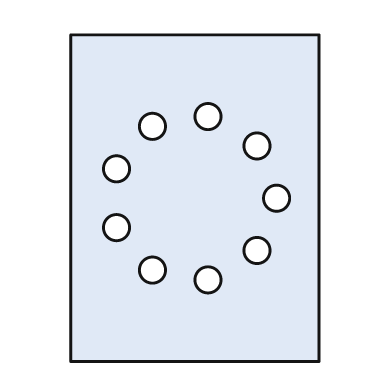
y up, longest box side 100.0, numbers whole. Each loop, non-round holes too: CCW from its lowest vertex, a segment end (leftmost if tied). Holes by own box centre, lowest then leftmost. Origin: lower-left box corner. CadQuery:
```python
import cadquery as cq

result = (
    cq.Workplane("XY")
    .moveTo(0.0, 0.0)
    .lineTo(76.0, 0.0)
    .lineTo(76.0, 100.0)
    .lineTo(0.0, 100.0)
    .close()
    .moveTo(42.0, 25.0)
    .circle(4.0)
    .moveTo(25.0, 28.0)
    .circle(4.0)
    .moveTo(57.0, 34.0)
    .circle(4.0)
    .moveTo(14.0, 41.0)
    .circle(4.0)
    .moveTo(63.0, 50.0)
    .circle(4.0)
    .moveTo(14.0, 59.0)
    .circle(4.0)
    .moveTo(57.0, 66.0)
    .circle(4.0)
    .moveTo(25.0, 72.0)
    .circle(4.0)
    .moveTo(42.0, 75.0)
    .circle(4.0)
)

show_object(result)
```